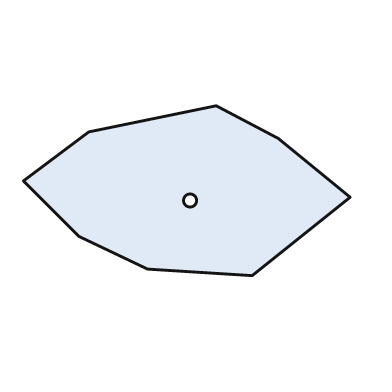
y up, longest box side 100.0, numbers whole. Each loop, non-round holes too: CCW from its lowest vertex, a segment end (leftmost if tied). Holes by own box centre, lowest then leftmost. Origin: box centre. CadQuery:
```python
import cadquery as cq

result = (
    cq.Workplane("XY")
    .moveTo(20.0, -26.0)
    .lineTo(50.0, -2.0)
    .lineTo(28.0, 16.0)
    .lineTo(9.0, 26.0)
    .lineTo(-30.0, 18.0)
    .lineTo(-50.0, 3.0)
    .lineTo(-33.0, -14.0)
    .lineTo(-12.0, -24.0)
    .close()
    .moveTo(1.0, -3.0)
    .circle(2.0)
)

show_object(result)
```